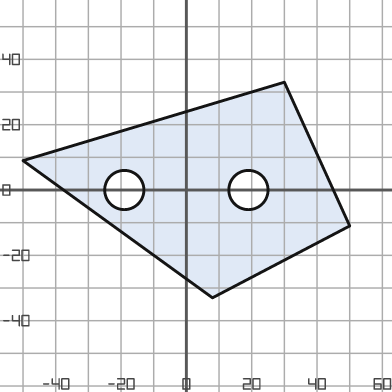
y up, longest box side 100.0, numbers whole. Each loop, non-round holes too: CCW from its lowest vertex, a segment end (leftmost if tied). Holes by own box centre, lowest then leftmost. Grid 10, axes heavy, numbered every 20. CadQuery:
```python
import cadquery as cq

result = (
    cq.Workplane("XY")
    .moveTo(8.0, -33.0)
    .lineTo(50.0, -11.0)
    .lineTo(30.0, 33.0)
    .lineTo(-50.0, 9.0)
    .close()
    .moveTo(-19.0, 0.0)
    .circle(6.0)
    .moveTo(19.0, 0.0)
    .circle(6.0)
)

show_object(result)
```